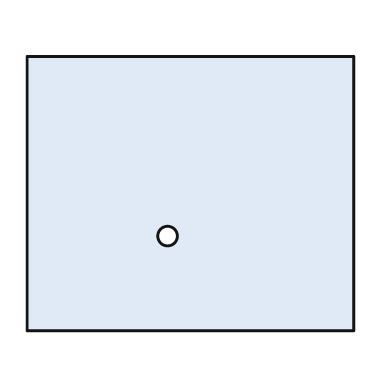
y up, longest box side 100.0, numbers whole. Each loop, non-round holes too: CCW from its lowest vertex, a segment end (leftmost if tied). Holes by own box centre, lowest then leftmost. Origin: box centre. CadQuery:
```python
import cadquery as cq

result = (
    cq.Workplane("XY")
    .moveTo(-50.0, -42.0)
    .lineTo(50.0, -42.0)
    .lineTo(50.0, 42.0)
    .lineTo(-50.0, 42.0)
    .close()
    .moveTo(-7.0, -13.0)
    .circle(3.0)
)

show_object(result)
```